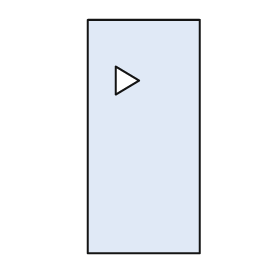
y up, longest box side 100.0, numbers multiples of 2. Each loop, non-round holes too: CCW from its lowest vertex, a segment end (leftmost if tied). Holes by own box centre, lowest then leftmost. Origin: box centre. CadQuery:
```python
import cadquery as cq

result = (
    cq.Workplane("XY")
    .moveTo(-24.0, -50.0)
    .lineTo(24.0, -50.0)
    .lineTo(24.0, 50.0)
    .lineTo(-24.0, 50.0)
    .close()
    .moveTo(-12.0, 18.0)
    .lineTo(-2.0, 24.0)
    .lineTo(-12.0, 30.0)
    .close()
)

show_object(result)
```